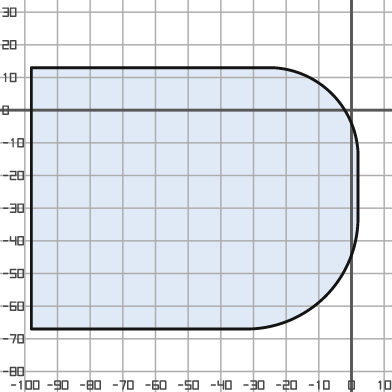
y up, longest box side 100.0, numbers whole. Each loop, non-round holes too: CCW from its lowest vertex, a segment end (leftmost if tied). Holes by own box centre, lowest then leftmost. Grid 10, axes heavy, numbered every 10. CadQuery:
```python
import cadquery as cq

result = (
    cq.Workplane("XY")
    .moveTo(-98.0, -67.0)
    .lineTo(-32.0, -67.0)
    .threePointArc((-8.0, -57.0), (2.0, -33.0))
    .lineTo(2.0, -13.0)
    .threePointArc((-6.0, 5.0), (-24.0, 13.0))
    .lineTo(-98.0, 13.0)
    .close()
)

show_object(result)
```